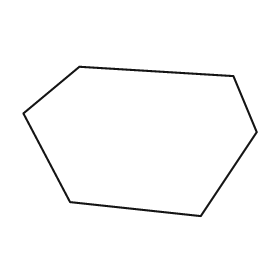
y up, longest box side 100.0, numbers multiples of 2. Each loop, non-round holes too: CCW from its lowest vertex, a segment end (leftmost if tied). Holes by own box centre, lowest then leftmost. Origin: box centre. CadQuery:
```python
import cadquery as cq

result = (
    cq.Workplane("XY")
    .moveTo(26.0, -32.0)
    .lineTo(50.0, 4.0)
    .lineTo(40.0, 28.0)
    .lineTo(-26.0, 32.0)
    .lineTo(-50.0, 12.0)
    .lineTo(-30.0, -26.0)
    .close()
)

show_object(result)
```